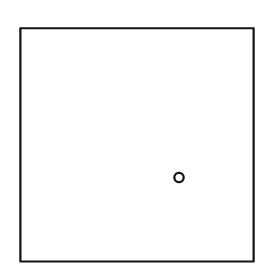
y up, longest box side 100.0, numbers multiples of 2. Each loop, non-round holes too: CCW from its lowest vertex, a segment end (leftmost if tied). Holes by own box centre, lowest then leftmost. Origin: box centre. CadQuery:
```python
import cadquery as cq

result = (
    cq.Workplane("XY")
    .moveTo(-50.0, -50.0)
    .lineTo(50.0, -50.0)
    .lineTo(50.0, 50.0)
    .lineTo(-50.0, 50.0)
    .close()
    .moveTo(18.0, -14.0)
    .circle(2.0)
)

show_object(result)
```